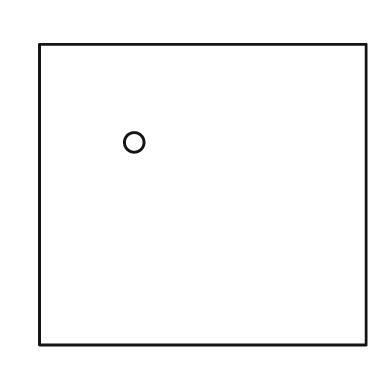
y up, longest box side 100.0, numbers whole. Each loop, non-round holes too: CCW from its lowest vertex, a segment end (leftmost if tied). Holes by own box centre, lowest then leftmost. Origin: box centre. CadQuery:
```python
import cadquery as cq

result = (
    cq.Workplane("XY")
    .moveTo(-50.0, -46.0)
    .lineTo(50.0, -46.0)
    .lineTo(50.0, 46.0)
    .lineTo(-50.0, 46.0)
    .close()
    .moveTo(-21.0, 16.0)
    .circle(3.0)
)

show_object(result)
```